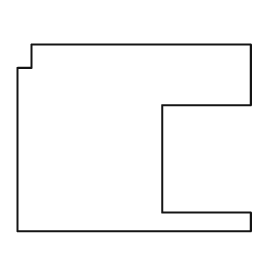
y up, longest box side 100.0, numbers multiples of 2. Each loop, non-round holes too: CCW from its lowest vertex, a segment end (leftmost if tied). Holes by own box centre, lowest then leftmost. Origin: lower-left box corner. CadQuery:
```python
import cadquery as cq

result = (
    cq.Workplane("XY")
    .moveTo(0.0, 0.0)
    .lineTo(100.0, 0.0)
    .lineTo(100.0, 8.0)
    .lineTo(62.0, 8.0)
    .lineTo(62.0, 54.0)
    .lineTo(100.0, 54.0)
    .lineTo(100.0, 80.0)
    .lineTo(6.0, 80.0)
    .lineTo(6.0, 70.0)
    .lineTo(0.0, 70.0)
    .close()
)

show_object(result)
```